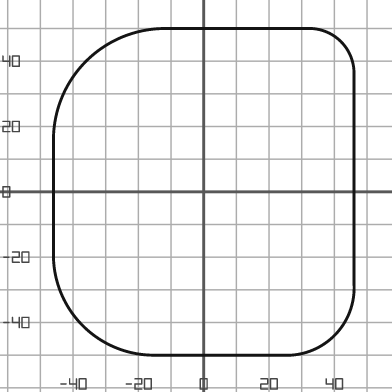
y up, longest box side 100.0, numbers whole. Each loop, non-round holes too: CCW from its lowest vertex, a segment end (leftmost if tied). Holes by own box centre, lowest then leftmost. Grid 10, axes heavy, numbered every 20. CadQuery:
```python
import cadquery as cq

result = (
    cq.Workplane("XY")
    .moveTo(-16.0, -50.0)
    .lineTo(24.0, -50.0)
    .threePointArc((40.0, -44.0), (46.0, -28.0))
    .lineTo(46.0, 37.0)
    .threePointArc((42.0, 46.0), (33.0, 50.0))
    .lineTo(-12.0, 50.0)
    .threePointArc((-36.0, 40.0), (-46.0, 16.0))
    .lineTo(-46.0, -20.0)
    .threePointArc((-37.0, -41.0), (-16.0, -50.0))
    .close()
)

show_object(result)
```